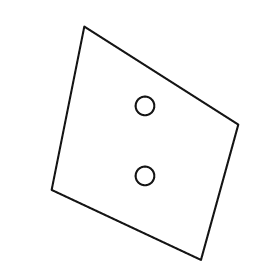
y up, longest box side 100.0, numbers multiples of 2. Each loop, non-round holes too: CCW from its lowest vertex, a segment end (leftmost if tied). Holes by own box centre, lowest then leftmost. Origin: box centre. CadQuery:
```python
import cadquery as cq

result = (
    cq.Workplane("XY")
    .moveTo(24.0, -50.0)
    .lineTo(40.0, 8.0)
    .lineTo(-26.0, 50.0)
    .lineTo(-40.0, -20.0)
    .close()
    .moveTo(0.0, -14.0)
    .circle(4.0)
    .moveTo(0.0, 16.0)
    .circle(4.0)
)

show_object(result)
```